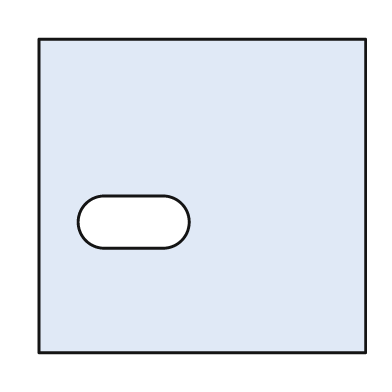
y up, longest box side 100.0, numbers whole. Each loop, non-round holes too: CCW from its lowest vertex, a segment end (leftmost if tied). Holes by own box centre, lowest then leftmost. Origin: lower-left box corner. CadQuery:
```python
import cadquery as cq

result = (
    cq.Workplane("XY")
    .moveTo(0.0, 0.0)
    .lineTo(100.0, 0.0)
    .lineTo(100.0, 96.0)
    .lineTo(0.0, 96.0)
    .close()
    .moveTo(20.0, 32.0)
    .lineTo(38.0, 32.0)
    .threePointArc((46.0, 40.0), (38.0, 48.0))
    .lineTo(20.0, 48.0)
    .threePointArc((12.0, 40.0), (20.0, 32.0))
    .close()
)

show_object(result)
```